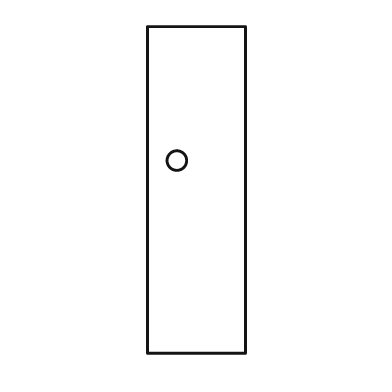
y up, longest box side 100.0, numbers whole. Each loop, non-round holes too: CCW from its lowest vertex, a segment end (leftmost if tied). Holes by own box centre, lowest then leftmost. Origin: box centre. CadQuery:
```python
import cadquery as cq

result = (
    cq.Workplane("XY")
    .moveTo(-15.0, -50.0)
    .lineTo(15.0, -50.0)
    .lineTo(15.0, 50.0)
    .lineTo(-15.0, 50.0)
    .close()
    .moveTo(-6.0, 9.0)
    .circle(3.0)
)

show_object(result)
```